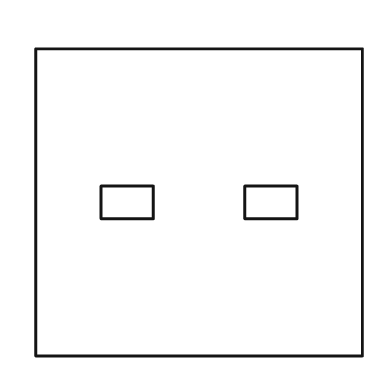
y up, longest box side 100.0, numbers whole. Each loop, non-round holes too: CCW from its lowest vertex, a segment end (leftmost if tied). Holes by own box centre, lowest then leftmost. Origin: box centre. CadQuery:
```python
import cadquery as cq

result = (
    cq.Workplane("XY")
    .moveTo(-50.0, -47.0)
    .lineTo(50.0, -47.0)
    .lineTo(50.0, 47.0)
    .lineTo(-50.0, 47.0)
    .close()
    .moveTo(-30.0, -5.0)
    .lineTo(-14.0, -5.0)
    .lineTo(-14.0, 5.0)
    .lineTo(-30.0, 5.0)
    .close()
    .moveTo(14.0, -5.0)
    .lineTo(30.0, -5.0)
    .lineTo(30.0, 5.0)
    .lineTo(14.0, 5.0)
    .close()
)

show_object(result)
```